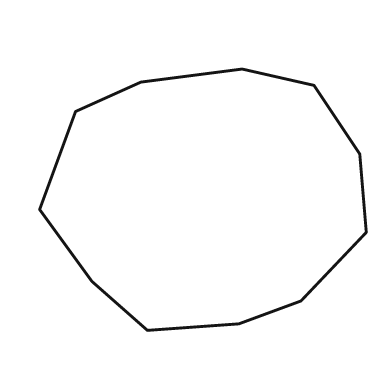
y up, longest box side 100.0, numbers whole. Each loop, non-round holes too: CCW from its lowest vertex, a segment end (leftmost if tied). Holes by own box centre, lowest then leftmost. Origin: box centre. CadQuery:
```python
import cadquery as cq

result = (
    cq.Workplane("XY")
    .moveTo(-17.0, -40.0)
    .lineTo(11.0, -38.0)
    .lineTo(30.0, -31.0)
    .lineTo(50.0, -10.0)
    .lineTo(48.0, 14.0)
    .lineTo(34.0, 35.0)
    .lineTo(12.0, 40.0)
    .lineTo(-19.0, 36.0)
    .lineTo(-39.0, 27.0)
    .lineTo(-50.0, -3.0)
    .lineTo(-34.0, -25.0)
    .close()
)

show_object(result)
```